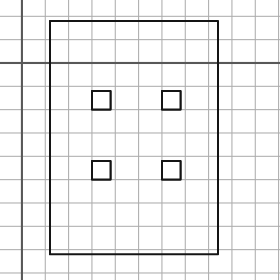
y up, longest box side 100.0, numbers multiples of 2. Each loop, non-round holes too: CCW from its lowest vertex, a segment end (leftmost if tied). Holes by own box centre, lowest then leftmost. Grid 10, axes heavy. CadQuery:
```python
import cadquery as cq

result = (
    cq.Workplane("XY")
    .moveTo(12.0, -82.0)
    .lineTo(84.0, -82.0)
    .lineTo(84.0, 18.0)
    .lineTo(12.0, 18.0)
    .close()
    .moveTo(30.0, -50.0)
    .lineTo(38.0, -50.0)
    .lineTo(38.0, -42.0)
    .lineTo(30.0, -42.0)
    .close()
    .moveTo(60.0, -50.0)
    .lineTo(68.0, -50.0)
    .lineTo(68.0, -42.0)
    .lineTo(60.0, -42.0)
    .close()
    .moveTo(30.0, -20.0)
    .lineTo(38.0, -20.0)
    .lineTo(38.0, -12.0)
    .lineTo(30.0, -12.0)
    .close()
    .moveTo(60.0, -20.0)
    .lineTo(68.0, -20.0)
    .lineTo(68.0, -12.0)
    .lineTo(60.0, -12.0)
    .close()
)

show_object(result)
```